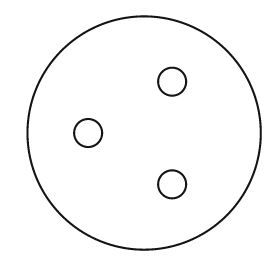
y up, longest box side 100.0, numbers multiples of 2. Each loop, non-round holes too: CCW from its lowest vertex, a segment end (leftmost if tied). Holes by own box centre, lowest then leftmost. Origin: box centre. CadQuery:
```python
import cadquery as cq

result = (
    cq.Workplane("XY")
    .moveTo(0.0, 0.0)
    .circle(50.0)
    .moveTo(12.0, -22.0)
    .circle(6.0)
    .moveTo(-24.0, 0.0)
    .circle(6.0)
    .moveTo(12.0, 22.0)
    .circle(6.0)
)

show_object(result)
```